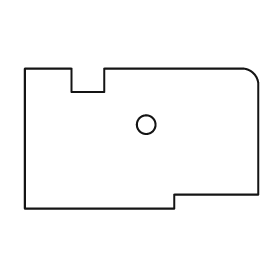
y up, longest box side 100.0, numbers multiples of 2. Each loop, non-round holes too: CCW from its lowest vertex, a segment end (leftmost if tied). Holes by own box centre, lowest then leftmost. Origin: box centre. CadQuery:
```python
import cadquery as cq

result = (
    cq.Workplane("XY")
    .moveTo(-50.0, -30.0)
    .lineTo(14.0, -30.0)
    .lineTo(14.0, -24.0)
    .lineTo(50.0, -24.0)
    .lineTo(50.0, 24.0)
    .threePointArc((48.0, 28.0), (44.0, 30.0))
    .lineTo(-16.0, 30.0)
    .lineTo(-16.0, 20.0)
    .lineTo(-30.0, 20.0)
    .lineTo(-30.0, 30.0)
    .lineTo(-50.0, 30.0)
    .close()
    .moveTo(2.0, 6.0)
    .circle(4.0)
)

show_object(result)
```